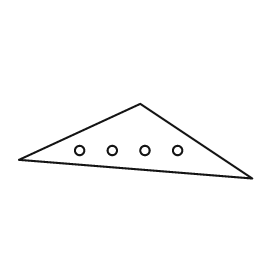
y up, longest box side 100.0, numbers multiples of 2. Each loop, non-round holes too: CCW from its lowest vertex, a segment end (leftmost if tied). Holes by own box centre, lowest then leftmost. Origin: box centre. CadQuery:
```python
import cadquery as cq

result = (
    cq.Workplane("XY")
    .moveTo(50.0, -16.0)
    .lineTo(2.0, 16.0)
    .lineTo(-50.0, -8.0)
    .close()
    .moveTo(-24.0, -4.0)
    .circle(2.0)
    .moveTo(-10.0, -4.0)
    .circle(2.0)
    .moveTo(4.0, -4.0)
    .circle(2.0)
    .moveTo(18.0, -4.0)
    .circle(2.0)
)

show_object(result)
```